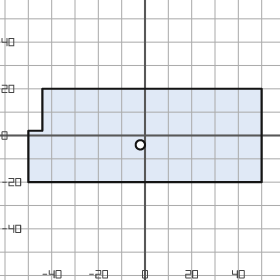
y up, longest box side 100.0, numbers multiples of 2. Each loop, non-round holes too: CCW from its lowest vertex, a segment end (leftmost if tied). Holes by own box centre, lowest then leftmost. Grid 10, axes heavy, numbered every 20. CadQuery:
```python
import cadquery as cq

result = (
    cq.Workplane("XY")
    .moveTo(-50.0, -20.0)
    .lineTo(50.0, -20.0)
    .lineTo(50.0, 20.0)
    .lineTo(-44.0, 20.0)
    .lineTo(-44.0, 2.0)
    .lineTo(-50.0, 2.0)
    .close()
    .moveTo(-2.0, -4.0)
    .circle(2.0)
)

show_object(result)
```